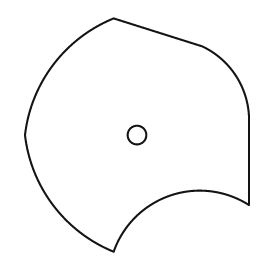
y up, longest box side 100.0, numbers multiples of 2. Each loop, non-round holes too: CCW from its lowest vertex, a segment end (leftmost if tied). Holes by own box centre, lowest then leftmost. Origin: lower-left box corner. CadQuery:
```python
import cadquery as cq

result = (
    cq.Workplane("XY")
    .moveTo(38.0, 0.0)
    .threePointArc((62.0, 24.0), (96.0, 20.0))
    .lineTo(96.0, 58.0)
    .threePointArc((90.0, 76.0), (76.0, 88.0))
    .lineTo(38.0, 100.0)
    .threePointArc((12.0, 80.0), (0.0, 50.0))
    .threePointArc((12.0, 20.0), (38.0, 0.0))
    .close()
    .moveTo(48.0, 50.0)
    .circle(4.0)
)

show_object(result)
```